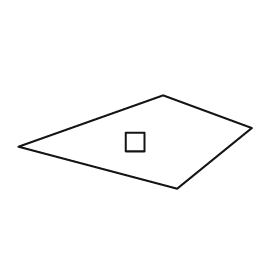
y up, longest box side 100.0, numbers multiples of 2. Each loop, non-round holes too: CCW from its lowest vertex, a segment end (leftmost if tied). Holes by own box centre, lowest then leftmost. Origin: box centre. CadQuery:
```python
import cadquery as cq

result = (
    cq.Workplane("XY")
    .moveTo(18.0, -20.0)
    .lineTo(50.0, 6.0)
    .lineTo(12.0, 20.0)
    .lineTo(-50.0, -2.0)
    .close()
    .moveTo(-4.0, -4.0)
    .lineTo(4.0, -4.0)
    .lineTo(4.0, 4.0)
    .lineTo(-4.0, 4.0)
    .close()
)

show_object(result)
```